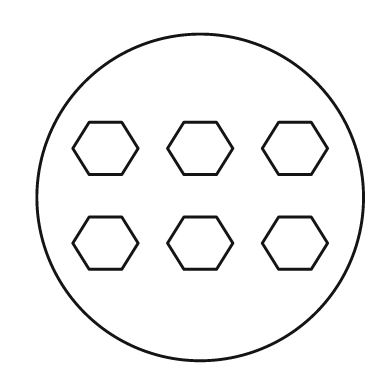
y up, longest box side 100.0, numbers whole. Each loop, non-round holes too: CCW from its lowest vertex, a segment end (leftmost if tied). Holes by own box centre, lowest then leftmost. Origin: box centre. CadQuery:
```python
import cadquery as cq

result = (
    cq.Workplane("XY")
    .moveTo(0.0, 0.0)
    .circle(50.0)
    .moveTo(-34.0, -22.0)
    .lineTo(-24.0, -22.0)
    .lineTo(-19.0, -14.0)
    .lineTo(-24.0, -6.0)
    .lineTo(-34.0, -6.0)
    .lineTo(-39.0, -14.0)
    .close()
    .moveTo(-5.0, -22.0)
    .lineTo(5.0, -22.0)
    .lineTo(10.0, -14.0)
    .lineTo(5.0, -6.0)
    .lineTo(-5.0, -6.0)
    .lineTo(-10.0, -14.0)
    .close()
    .moveTo(24.0, -22.0)
    .lineTo(34.0, -22.0)
    .lineTo(39.0, -14.0)
    .lineTo(34.0, -6.0)
    .lineTo(24.0, -6.0)
    .lineTo(19.0, -14.0)
    .close()
    .moveTo(-34.0, 7.0)
    .lineTo(-24.0, 7.0)
    .lineTo(-19.0, 15.0)
    .lineTo(-24.0, 23.0)
    .lineTo(-34.0, 23.0)
    .lineTo(-39.0, 15.0)
    .close()
    .moveTo(-5.0, 7.0)
    .lineTo(5.0, 7.0)
    .lineTo(10.0, 15.0)
    .lineTo(5.0, 23.0)
    .lineTo(-5.0, 23.0)
    .lineTo(-10.0, 15.0)
    .close()
    .moveTo(24.0, 7.0)
    .lineTo(34.0, 7.0)
    .lineTo(39.0, 15.0)
    .lineTo(34.0, 23.0)
    .lineTo(24.0, 23.0)
    .lineTo(19.0, 15.0)
    .close()
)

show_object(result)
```